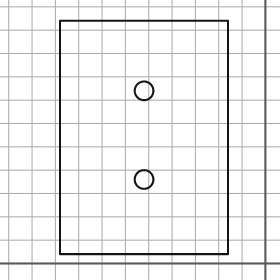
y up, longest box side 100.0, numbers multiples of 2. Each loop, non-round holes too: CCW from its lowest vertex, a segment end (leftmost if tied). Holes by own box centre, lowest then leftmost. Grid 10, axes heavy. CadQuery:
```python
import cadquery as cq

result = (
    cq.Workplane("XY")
    .moveTo(-88.0, 4.0)
    .lineTo(-16.0, 4.0)
    .lineTo(-16.0, 104.0)
    .lineTo(-88.0, 104.0)
    .close()
    .moveTo(-52.0, 36.0)
    .circle(4.0)
    .moveTo(-52.0, 74.0)
    .circle(4.0)
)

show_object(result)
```